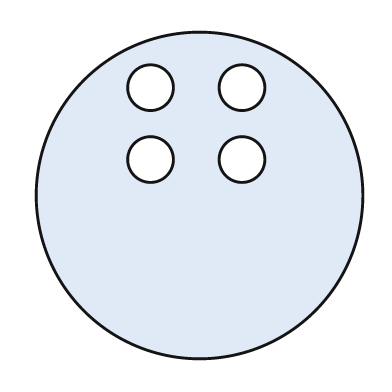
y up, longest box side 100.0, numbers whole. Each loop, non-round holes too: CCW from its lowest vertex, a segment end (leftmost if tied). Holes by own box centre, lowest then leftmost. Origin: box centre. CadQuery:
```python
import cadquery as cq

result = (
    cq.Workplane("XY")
    .moveTo(0.0, 0.0)
    .circle(50.0)
    .moveTo(-15.0, 11.0)
    .circle(7.0)
    .moveTo(13.0, 11.0)
    .circle(7.0)
    .moveTo(-15.0, 33.0)
    .circle(7.0)
    .moveTo(13.0, 33.0)
    .circle(7.0)
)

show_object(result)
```